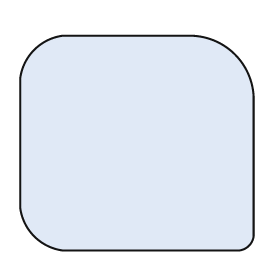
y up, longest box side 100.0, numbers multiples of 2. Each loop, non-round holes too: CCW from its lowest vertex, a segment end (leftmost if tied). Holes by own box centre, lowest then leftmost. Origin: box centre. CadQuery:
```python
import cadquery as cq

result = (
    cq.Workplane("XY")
    .moveTo(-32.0, -46.0)
    .lineTo(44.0, -46.0)
    .threePointArc((48.0, -44.0), (50.0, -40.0))
    .lineTo(50.0, 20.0)
    .threePointArc((42.0, 38.0), (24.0, 46.0))
    .lineTo(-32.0, 46.0)
    .threePointArc((-44.0, 40.0), (-50.0, 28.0))
    .lineTo(-50.0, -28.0)
    .threePointArc((-44.0, -40.0), (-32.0, -46.0))
    .close()
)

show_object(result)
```